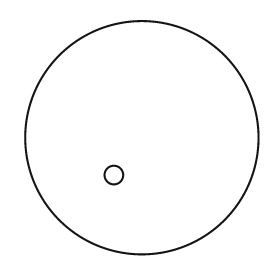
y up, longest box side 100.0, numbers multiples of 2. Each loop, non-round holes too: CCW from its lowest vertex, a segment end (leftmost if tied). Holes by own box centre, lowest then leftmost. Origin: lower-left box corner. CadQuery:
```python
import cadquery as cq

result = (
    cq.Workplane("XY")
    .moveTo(50.0, 50.0)
    .circle(50.0)
    .moveTo(38.0, 34.0)
    .circle(4.0)
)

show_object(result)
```